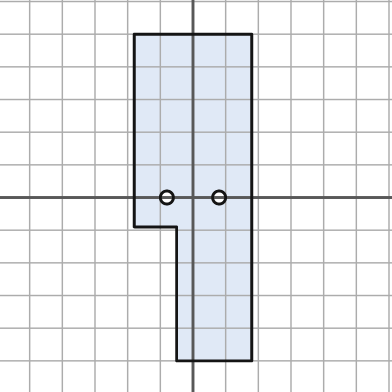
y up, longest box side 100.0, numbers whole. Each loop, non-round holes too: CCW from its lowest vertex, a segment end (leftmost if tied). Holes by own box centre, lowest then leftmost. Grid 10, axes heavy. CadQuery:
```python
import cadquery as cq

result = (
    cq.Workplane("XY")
    .moveTo(-5.0, -50.0)
    .lineTo(18.0, -50.0)
    .lineTo(18.0, 50.0)
    .lineTo(-18.0, 50.0)
    .lineTo(-18.0, -9.0)
    .lineTo(-5.0, -9.0)
    .close()
    .moveTo(-8.0, 0.0)
    .circle(2.0)
    .moveTo(8.0, 0.0)
    .circle(2.0)
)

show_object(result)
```